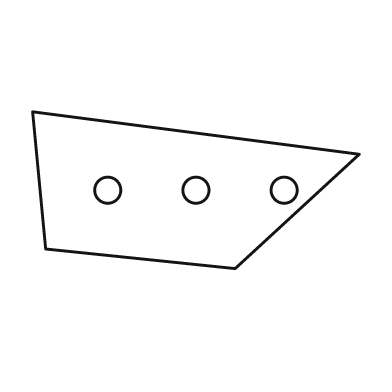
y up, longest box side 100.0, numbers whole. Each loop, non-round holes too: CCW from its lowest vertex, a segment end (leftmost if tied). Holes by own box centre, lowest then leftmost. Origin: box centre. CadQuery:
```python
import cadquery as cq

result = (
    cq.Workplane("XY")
    .moveTo(12.0, -24.0)
    .lineTo(50.0, 11.0)
    .lineTo(-50.0, 24.0)
    .lineTo(-46.0, -18.0)
    .close()
    .moveTo(-27.0, 0.0)
    .circle(4.0)
    .moveTo(0.0, 0.0)
    .circle(4.0)
    .moveTo(27.0, 0.0)
    .circle(4.0)
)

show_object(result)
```